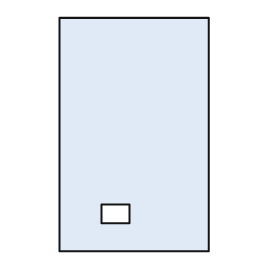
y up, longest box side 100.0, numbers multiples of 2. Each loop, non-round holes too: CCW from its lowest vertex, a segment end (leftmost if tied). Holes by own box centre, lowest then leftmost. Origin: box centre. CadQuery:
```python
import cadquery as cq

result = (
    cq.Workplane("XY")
    .moveTo(-32.0, -50.0)
    .lineTo(32.0, -50.0)
    .lineTo(32.0, 50.0)
    .lineTo(-32.0, 50.0)
    .close()
    .moveTo(-14.0, -38.0)
    .lineTo(-2.0, -38.0)
    .lineTo(-2.0, -30.0)
    .lineTo(-14.0, -30.0)
    .close()
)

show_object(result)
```